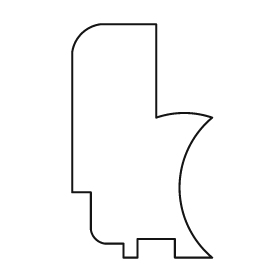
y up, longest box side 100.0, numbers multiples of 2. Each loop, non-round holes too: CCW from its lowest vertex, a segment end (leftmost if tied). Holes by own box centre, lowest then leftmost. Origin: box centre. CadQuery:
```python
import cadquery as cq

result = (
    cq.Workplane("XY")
    .moveTo(-8.0, -50.0)
    .lineTo(-2.0, -50.0)
    .lineTo(-2.0, -42.0)
    .lineTo(14.0, -42.0)
    .lineTo(14.0, -50.0)
    .lineTo(30.0, -50.0)
    .threePointArc((16.0, -20.0), (30.0, 10.0))
    .threePointArc((18.0, 12.0), (6.0, 10.0))
    .lineTo(6.0, 50.0)
    .lineTo(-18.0, 50.0)
    .threePointArc((-26.0, 46.0), (-30.0, 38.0))
    .lineTo(-30.0, -22.0)
    .lineTo(-22.0, -22.0)
    .lineTo(-22.0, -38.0)
    .threePointArc((-20.0, -42.0), (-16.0, -44.0))
    .lineTo(-8.0, -44.0)
    .close()
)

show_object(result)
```